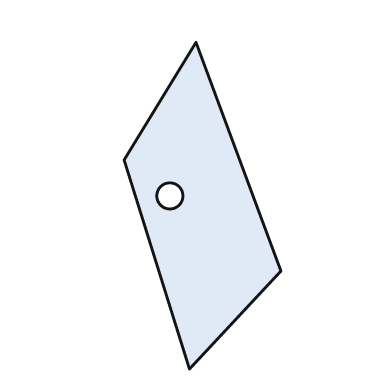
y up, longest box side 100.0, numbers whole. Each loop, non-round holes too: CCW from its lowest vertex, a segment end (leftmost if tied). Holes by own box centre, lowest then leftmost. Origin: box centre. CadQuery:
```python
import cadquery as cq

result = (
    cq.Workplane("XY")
    .moveTo(-4.0, -50.0)
    .lineTo(24.0, -20.0)
    .lineTo(-2.0, 50.0)
    .lineTo(-24.0, 14.0)
    .close()
    .moveTo(-10.0, 3.0)
    .circle(4.0)
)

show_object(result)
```